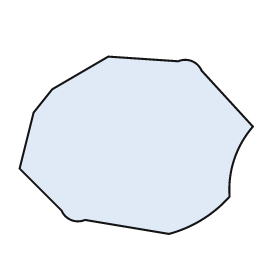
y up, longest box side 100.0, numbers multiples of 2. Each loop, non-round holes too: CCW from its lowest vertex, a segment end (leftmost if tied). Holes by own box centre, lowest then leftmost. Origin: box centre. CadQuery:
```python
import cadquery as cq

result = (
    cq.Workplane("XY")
    .moveTo(14.0, -38.0)
    .threePointArc((28.0, -32.0), (40.0, -22.0))
    .threePointArc((42.0, -6.0), (50.0, 8.0))
    .lineTo(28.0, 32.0)
    .threePointArc((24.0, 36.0), (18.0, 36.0))
    .lineTo(-12.0, 38.0)
    .lineTo(-36.0, 24.0)
    .lineTo(-44.0, 14.0)
    .lineTo(-50.0, -10.0)
    .lineTo(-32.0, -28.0)
    .threePointArc((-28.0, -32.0), (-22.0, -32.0))
    .close()
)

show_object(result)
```